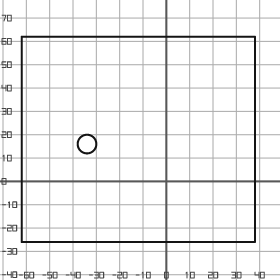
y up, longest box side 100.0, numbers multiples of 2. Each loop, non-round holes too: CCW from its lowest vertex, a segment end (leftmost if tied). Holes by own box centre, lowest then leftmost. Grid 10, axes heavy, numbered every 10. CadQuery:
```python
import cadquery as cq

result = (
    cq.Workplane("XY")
    .moveTo(-62.0, -26.0)
    .lineTo(38.0, -26.0)
    .lineTo(38.0, 62.0)
    .lineTo(-62.0, 62.0)
    .close()
    .moveTo(-34.0, 16.0)
    .circle(4.0)
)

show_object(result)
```